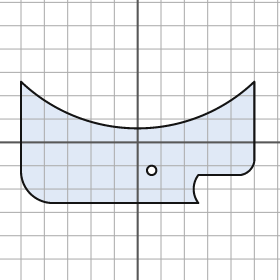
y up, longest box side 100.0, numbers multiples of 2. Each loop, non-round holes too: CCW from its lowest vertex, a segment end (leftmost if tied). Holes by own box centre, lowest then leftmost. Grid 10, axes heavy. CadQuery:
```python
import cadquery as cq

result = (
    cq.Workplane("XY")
    .moveTo(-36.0, -26.0)
    .lineTo(26.0, -26.0)
    .threePointArc((24.0, -20.0), (26.0, -14.0))
    .lineTo(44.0, -14.0)
    .threePointArc((48.0, -12.0), (50.0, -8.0))
    .lineTo(50.0, 26.0)
    .threePointArc((0.0, 6.0), (-50.0, 26.0))
    .lineTo(-50.0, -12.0)
    .threePointArc((-46.0, -22.0), (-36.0, -26.0))
    .close()
    .moveTo(6.0, -12.0)
    .circle(2.0)
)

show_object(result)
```